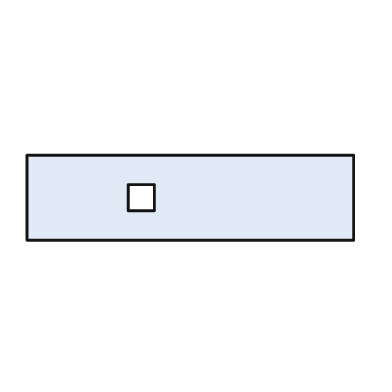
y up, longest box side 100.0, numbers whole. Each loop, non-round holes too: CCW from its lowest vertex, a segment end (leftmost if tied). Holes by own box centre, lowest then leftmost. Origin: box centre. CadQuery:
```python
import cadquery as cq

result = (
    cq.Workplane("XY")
    .moveTo(-50.0, -13.0)
    .lineTo(50.0, -13.0)
    .lineTo(50.0, 13.0)
    .lineTo(-50.0, 13.0)
    .close()
    .moveTo(-19.0, -4.0)
    .lineTo(-11.0, -4.0)
    .lineTo(-11.0, 4.0)
    .lineTo(-19.0, 4.0)
    .close()
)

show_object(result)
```